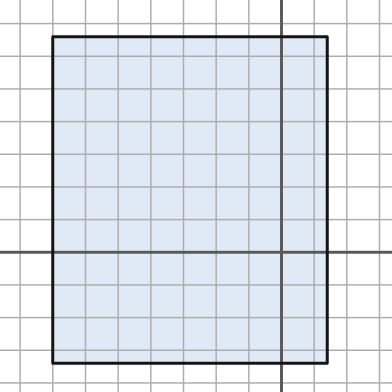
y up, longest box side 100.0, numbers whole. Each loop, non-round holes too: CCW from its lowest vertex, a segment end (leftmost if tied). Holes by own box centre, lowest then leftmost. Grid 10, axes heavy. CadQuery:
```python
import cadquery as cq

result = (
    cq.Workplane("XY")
    .moveTo(-70.0, -34.0)
    .lineTo(14.0, -34.0)
    .lineTo(14.0, 66.0)
    .lineTo(-70.0, 66.0)
    .close()
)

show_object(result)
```